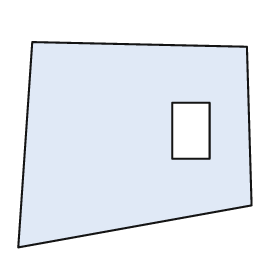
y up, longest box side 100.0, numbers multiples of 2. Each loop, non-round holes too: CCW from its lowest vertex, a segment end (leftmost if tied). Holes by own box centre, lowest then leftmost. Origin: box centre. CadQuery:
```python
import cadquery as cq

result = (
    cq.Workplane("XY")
    .moveTo(-50.0, -44.0)
    .lineTo(50.0, -26.0)
    .lineTo(48.0, 42.0)
    .lineTo(-44.0, 44.0)
    .close()
    .moveTo(16.0, -6.0)
    .lineTo(32.0, -6.0)
    .lineTo(32.0, 18.0)
    .lineTo(16.0, 18.0)
    .close()
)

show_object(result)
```